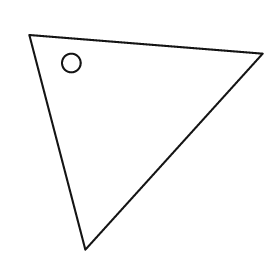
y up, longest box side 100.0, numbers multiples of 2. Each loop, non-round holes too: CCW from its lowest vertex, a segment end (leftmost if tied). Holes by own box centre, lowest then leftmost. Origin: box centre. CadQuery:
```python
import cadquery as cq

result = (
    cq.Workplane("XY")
    .moveTo(-26.0, -46.0)
    .lineTo(50.0, 38.0)
    .lineTo(-50.0, 46.0)
    .close()
    .moveTo(-32.0, 34.0)
    .circle(4.0)
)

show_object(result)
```